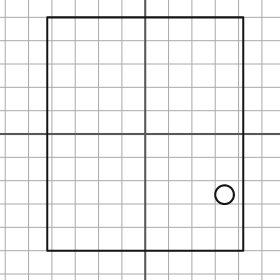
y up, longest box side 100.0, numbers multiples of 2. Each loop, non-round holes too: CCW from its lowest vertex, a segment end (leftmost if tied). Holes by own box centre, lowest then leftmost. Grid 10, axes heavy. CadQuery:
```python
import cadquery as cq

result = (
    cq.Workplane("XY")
    .moveTo(-42.0, -50.0)
    .lineTo(42.0, -50.0)
    .lineTo(42.0, 50.0)
    .lineTo(-42.0, 50.0)
    .close()
    .moveTo(34.0, -26.0)
    .circle(4.0)
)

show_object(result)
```